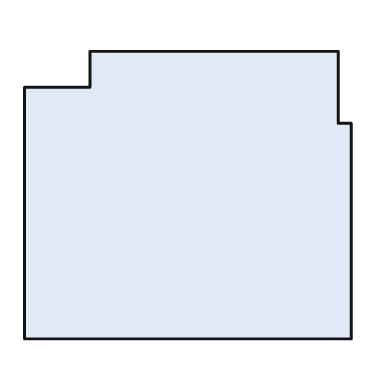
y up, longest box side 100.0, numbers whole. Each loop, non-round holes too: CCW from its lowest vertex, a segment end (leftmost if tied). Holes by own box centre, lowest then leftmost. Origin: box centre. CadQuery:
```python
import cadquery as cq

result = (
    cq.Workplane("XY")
    .moveTo(-50.0, -44.0)
    .lineTo(50.0, -44.0)
    .lineTo(50.0, 22.0)
    .lineTo(46.0, 22.0)
    .lineTo(46.0, 44.0)
    .lineTo(-30.0, 44.0)
    .lineTo(-30.0, 33.0)
    .lineTo(-50.0, 33.0)
    .close()
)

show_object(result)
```